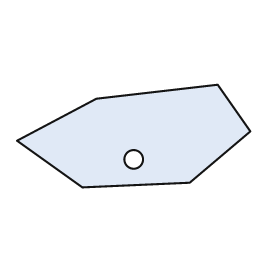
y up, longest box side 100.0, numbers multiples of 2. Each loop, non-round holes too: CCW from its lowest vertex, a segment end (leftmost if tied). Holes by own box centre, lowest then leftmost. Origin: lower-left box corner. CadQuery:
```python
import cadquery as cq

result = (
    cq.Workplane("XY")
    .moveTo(28.0, 0.0)
    .lineTo(74.0, 2.0)
    .lineTo(100.0, 24.0)
    .lineTo(86.0, 44.0)
    .lineTo(34.0, 38.0)
    .lineTo(0.0, 20.0)
    .close()
    .moveTo(50.0, 12.0)
    .circle(4.0)
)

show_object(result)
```